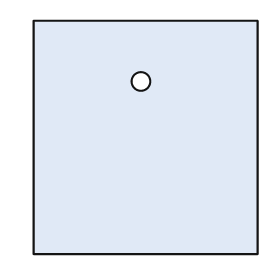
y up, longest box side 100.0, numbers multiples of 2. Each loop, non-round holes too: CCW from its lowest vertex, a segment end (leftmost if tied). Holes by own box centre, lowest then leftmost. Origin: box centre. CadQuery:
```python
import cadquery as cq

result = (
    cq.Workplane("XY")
    .moveTo(-48.0, -50.0)
    .lineTo(48.0, -50.0)
    .lineTo(48.0, 50.0)
    .lineTo(-48.0, 50.0)
    .close()
    .moveTo(-2.0, 24.0)
    .circle(4.0)
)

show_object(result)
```